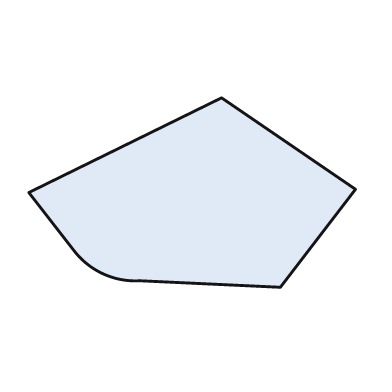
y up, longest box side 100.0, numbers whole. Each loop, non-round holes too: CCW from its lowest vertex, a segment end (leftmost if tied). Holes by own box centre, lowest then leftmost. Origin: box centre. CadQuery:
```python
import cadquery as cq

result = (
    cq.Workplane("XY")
    .moveTo(27.0, -29.0)
    .lineTo(50.0, 1.0)
    .lineTo(9.0, 29.0)
    .lineTo(-50.0, 0.0)
    .lineTo(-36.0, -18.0)
    .threePointArc((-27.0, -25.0), (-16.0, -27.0))
    .close()
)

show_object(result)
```